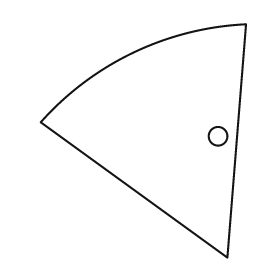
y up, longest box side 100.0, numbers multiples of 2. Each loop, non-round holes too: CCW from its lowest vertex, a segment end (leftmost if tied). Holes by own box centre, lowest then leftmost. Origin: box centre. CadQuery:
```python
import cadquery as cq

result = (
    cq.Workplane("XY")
    .moveTo(36.0, -50.0)
    .lineTo(44.0, 50.0)
    .threePointArc((-4.0, 38.0), (-44.0, 8.0))
    .close()
    .moveTo(32.0, 2.0)
    .circle(4.0)
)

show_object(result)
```